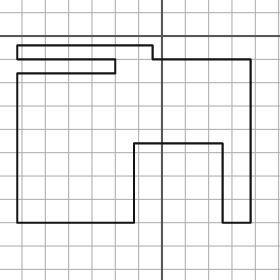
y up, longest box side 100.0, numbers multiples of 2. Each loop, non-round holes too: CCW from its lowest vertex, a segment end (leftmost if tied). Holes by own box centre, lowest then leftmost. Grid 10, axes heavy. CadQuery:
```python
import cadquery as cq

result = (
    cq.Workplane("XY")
    .moveTo(-62.0, -80.0)
    .lineTo(-12.0, -80.0)
    .lineTo(-12.0, -46.0)
    .lineTo(26.0, -46.0)
    .lineTo(26.0, -80.0)
    .lineTo(38.0, -80.0)
    .lineTo(38.0, -10.0)
    .lineTo(-4.0, -10.0)
    .lineTo(-4.0, -4.0)
    .lineTo(-62.0, -4.0)
    .lineTo(-62.0, -10.0)
    .lineTo(-20.0, -10.0)
    .lineTo(-20.0, -16.0)
    .lineTo(-62.0, -16.0)
    .close()
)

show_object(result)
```